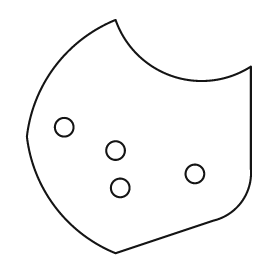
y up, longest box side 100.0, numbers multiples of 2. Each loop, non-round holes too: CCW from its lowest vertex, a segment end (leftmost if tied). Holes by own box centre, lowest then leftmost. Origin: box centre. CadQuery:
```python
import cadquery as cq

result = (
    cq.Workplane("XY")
    .moveTo(-10.0, -50.0)
    .lineTo(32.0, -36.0)
    .threePointArc((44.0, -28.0), (48.0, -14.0))
    .lineTo(48.0, 30.0)
    .threePointArc((14.0, 26.0), (-10.0, 50.0))
    .threePointArc((-36.0, 30.0), (-48.0, 0.0))
    .threePointArc((-36.0, -30.0), (-10.0, -50.0))
    .close()
    .moveTo(-8.0, -22.0)
    .circle(4.0)
    .moveTo(24.0, -16.0)
    .circle(4.0)
    .moveTo(-10.0, -6.0)
    .circle(4.0)
    .moveTo(-32.0, 4.0)
    .circle(4.0)
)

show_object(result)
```